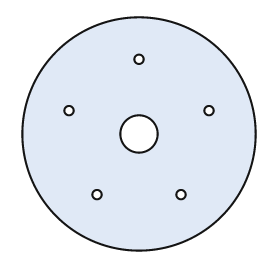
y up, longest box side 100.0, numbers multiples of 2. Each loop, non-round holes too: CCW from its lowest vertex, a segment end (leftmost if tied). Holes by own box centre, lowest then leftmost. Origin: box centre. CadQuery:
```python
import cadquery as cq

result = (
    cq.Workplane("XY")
    .moveTo(0.0, 0.0)
    .circle(50.0)
    .moveTo(-18.0, -26.0)
    .circle(2.0)
    .moveTo(18.0, -26.0)
    .circle(2.0)
    .moveTo(0.0, 0.0)
    .circle(8.0)
    .moveTo(-30.0, 10.0)
    .circle(2.0)
    .moveTo(30.0, 10.0)
    .circle(2.0)
    .moveTo(0.0, 32.0)
    .circle(2.0)
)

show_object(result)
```